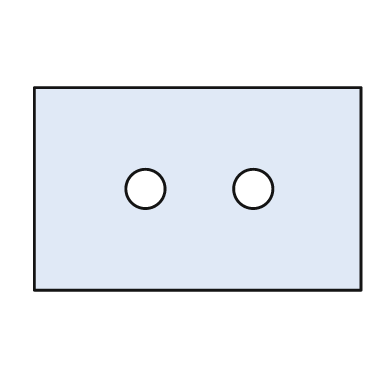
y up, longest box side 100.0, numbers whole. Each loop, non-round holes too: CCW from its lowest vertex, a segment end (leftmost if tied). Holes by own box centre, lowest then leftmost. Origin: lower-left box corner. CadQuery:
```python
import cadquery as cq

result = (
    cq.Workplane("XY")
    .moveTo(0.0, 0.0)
    .lineTo(100.0, 0.0)
    .lineTo(100.0, 62.0)
    .lineTo(0.0, 62.0)
    .close()
    .moveTo(34.0, 31.0)
    .circle(6.0)
    .moveTo(67.0, 31.0)
    .circle(6.0)
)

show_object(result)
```